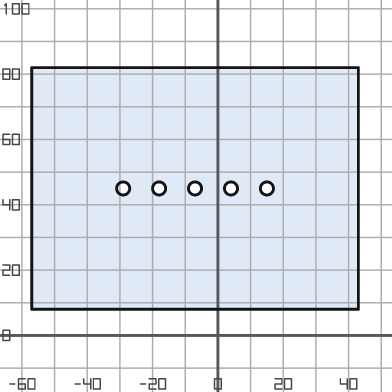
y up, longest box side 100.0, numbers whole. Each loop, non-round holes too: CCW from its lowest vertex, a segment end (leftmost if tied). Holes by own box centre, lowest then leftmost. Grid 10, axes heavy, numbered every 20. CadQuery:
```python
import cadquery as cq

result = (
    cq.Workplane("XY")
    .moveTo(-57.0, 8.0)
    .lineTo(43.0, 8.0)
    .lineTo(43.0, 82.0)
    .lineTo(-57.0, 82.0)
    .close()
    .moveTo(-29.0, 45.0)
    .circle(2.0)
    .moveTo(-18.0, 45.0)
    .circle(2.0)
    .moveTo(-7.0, 45.0)
    .circle(2.0)
    .moveTo(4.0, 45.0)
    .circle(2.0)
    .moveTo(15.0, 45.0)
    .circle(2.0)
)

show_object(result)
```